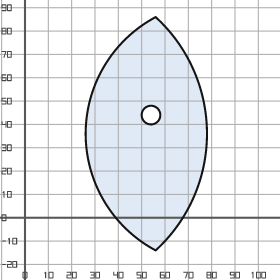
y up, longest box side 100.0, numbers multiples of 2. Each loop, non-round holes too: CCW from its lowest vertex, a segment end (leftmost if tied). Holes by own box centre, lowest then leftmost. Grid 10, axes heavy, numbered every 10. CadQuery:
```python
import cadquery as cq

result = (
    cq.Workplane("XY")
    .moveTo(56.0, -14.0)
    .threePointArc((78.0, 36.0), (56.0, 86.0))
    .threePointArc((26.0, 36.0), (56.0, -14.0))
    .close()
    .moveTo(54.0, 44.0)
    .circle(4.0)
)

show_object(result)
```